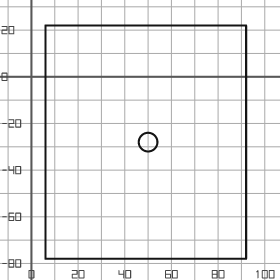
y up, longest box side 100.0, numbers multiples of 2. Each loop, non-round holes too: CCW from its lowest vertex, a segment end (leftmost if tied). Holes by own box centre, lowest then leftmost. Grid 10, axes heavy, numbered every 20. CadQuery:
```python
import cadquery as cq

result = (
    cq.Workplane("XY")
    .moveTo(6.0, -78.0)
    .lineTo(92.0, -78.0)
    .lineTo(92.0, 22.0)
    .lineTo(6.0, 22.0)
    .close()
    .moveTo(50.0, -28.0)
    .circle(4.0)
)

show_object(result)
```